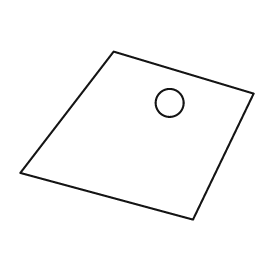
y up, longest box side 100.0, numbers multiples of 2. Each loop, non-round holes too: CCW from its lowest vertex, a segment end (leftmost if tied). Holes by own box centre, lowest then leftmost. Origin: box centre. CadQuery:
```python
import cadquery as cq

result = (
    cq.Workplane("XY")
    .moveTo(24.0, -36.0)
    .lineTo(50.0, 18.0)
    .lineTo(-10.0, 36.0)
    .lineTo(-50.0, -16.0)
    .close()
    .moveTo(14.0, 14.0)
    .circle(6.0)
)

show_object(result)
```